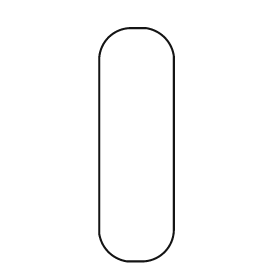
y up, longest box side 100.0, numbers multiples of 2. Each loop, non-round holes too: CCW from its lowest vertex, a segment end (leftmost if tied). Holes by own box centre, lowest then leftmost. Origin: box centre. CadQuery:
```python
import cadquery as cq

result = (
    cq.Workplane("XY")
    .moveTo(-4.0, -50.0)
    .lineTo(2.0, -50.0)
    .threePointArc((12.0, -46.0), (16.0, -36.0))
    .lineTo(16.0, 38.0)
    .threePointArc((12.0, 46.0), (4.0, 50.0))
    .lineTo(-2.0, 50.0)
    .threePointArc((-12.0, 46.0), (-16.0, 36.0))
    .lineTo(-16.0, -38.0)
    .threePointArc((-12.0, -46.0), (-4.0, -50.0))
    .close()
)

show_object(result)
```